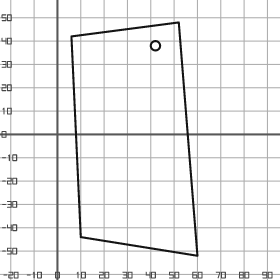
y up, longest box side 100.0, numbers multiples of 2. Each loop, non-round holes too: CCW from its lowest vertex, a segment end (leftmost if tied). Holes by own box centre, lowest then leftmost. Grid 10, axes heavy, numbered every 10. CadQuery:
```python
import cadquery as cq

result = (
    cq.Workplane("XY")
    .moveTo(60.0, -52.0)
    .lineTo(52.0, 48.0)
    .lineTo(6.0, 42.0)
    .lineTo(10.0, -44.0)
    .close()
    .moveTo(42.0, 38.0)
    .circle(2.0)
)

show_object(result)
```